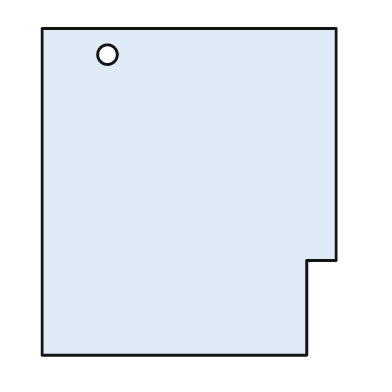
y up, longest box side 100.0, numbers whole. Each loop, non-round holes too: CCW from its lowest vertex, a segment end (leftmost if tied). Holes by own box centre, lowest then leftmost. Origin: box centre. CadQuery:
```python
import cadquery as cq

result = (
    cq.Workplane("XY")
    .moveTo(-45.0, -50.0)
    .lineTo(36.0, -50.0)
    .lineTo(36.0, -21.0)
    .lineTo(45.0, -21.0)
    .lineTo(45.0, 50.0)
    .lineTo(-45.0, 50.0)
    .close()
    .moveTo(-25.0, 42.0)
    .circle(3.0)
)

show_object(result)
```